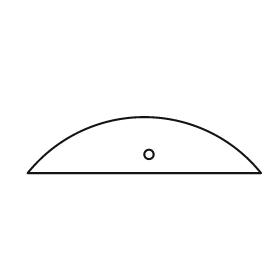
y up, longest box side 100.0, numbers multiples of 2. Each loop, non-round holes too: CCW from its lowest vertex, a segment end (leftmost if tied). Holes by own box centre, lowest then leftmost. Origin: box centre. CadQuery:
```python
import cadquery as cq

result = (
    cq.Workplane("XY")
    .moveTo(-50.0, -12.0)
    .lineTo(50.0, -12.0)
    .threePointArc((0.0, 12.0), (-50.0, -12.0))
    .close()
    .moveTo(2.0, -4.0)
    .circle(2.0)
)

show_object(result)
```